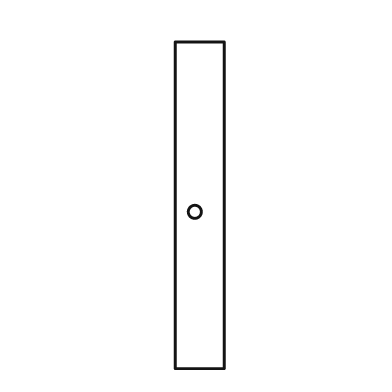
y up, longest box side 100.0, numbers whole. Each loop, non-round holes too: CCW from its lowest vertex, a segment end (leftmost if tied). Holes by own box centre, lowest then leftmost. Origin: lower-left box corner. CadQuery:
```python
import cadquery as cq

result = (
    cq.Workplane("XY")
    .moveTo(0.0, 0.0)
    .lineTo(15.0, 0.0)
    .lineTo(15.0, 100.0)
    .lineTo(0.0, 100.0)
    .close()
    .moveTo(6.0, 48.0)
    .circle(2.0)
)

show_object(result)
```